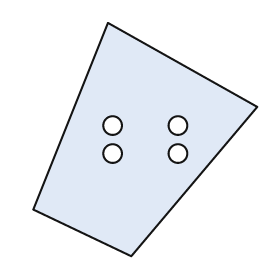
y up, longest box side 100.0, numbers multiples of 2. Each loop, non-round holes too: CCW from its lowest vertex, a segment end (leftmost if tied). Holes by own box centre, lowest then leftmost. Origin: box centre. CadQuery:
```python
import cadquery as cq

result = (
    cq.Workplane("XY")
    .moveTo(-6.0, -50.0)
    .lineTo(48.0, 14.0)
    .lineTo(-16.0, 50.0)
    .lineTo(-48.0, -30.0)
    .close()
    .moveTo(-14.0, -6.0)
    .circle(4.0)
    .moveTo(14.0, -6.0)
    .circle(4.0)
    .moveTo(-14.0, 6.0)
    .circle(4.0)
    .moveTo(14.0, 6.0)
    .circle(4.0)
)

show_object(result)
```